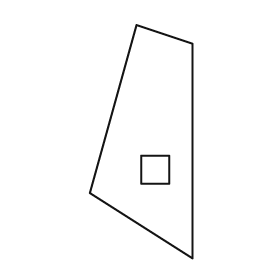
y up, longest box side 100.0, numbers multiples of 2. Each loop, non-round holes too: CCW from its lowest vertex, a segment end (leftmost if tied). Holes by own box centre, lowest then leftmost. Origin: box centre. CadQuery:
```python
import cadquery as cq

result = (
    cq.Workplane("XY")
    .moveTo(22.0, -50.0)
    .lineTo(22.0, 42.0)
    .lineTo(-2.0, 50.0)
    .lineTo(-22.0, -22.0)
    .close()
    .moveTo(0.0, -18.0)
    .lineTo(12.0, -18.0)
    .lineTo(12.0, -6.0)
    .lineTo(0.0, -6.0)
    .close()
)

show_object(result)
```